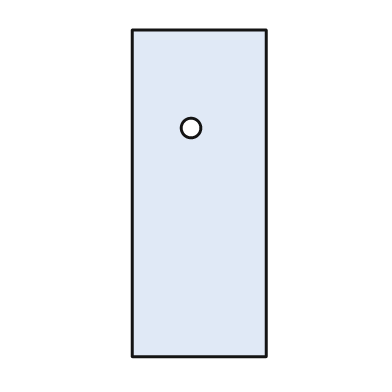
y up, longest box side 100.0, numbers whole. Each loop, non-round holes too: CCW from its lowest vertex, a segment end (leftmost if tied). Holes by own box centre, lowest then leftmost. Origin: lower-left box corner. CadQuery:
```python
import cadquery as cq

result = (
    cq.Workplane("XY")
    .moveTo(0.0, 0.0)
    .lineTo(41.0, 0.0)
    .lineTo(41.0, 100.0)
    .lineTo(0.0, 100.0)
    .close()
    .moveTo(18.0, 70.0)
    .circle(3.0)
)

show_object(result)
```